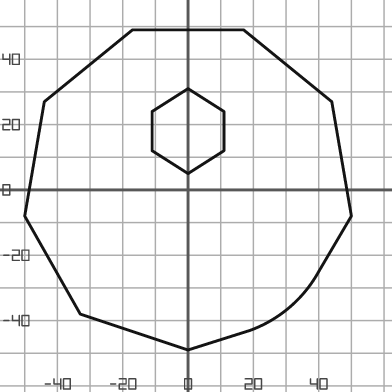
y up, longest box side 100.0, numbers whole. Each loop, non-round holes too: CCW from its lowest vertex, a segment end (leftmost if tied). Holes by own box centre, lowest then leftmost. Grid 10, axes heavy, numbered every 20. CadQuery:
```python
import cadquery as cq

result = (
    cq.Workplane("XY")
    .moveTo(0.0, -49.0)
    .lineTo(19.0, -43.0)
    .threePointArc((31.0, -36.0), (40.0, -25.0))
    .lineTo(50.0, -8.0)
    .lineTo(44.0, 27.0)
    .lineTo(17.0, 49.0)
    .lineTo(-17.0, 49.0)
    .lineTo(-44.0, 27.0)
    .lineTo(-50.0, -8.0)
    .lineTo(-33.0, -38.0)
    .close()
    .moveTo(0.0, 5.0)
    .lineTo(11.0, 12.0)
    .lineTo(11.0, 24.0)
    .lineTo(0.0, 31.0)
    .lineTo(-11.0, 24.0)
    .lineTo(-11.0, 12.0)
    .close()
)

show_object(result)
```